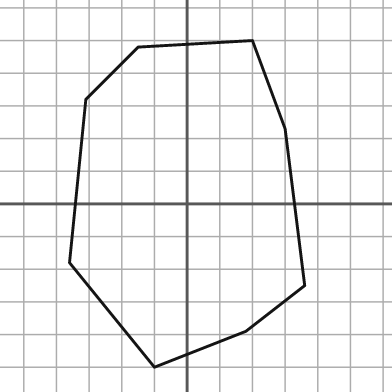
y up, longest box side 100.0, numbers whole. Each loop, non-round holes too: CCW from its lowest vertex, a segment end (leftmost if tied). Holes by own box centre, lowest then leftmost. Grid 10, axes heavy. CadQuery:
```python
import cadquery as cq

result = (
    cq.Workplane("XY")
    .moveTo(-10.0, -50.0)
    .lineTo(18.0, -39.0)
    .lineTo(36.0, -25.0)
    .lineTo(30.0, 23.0)
    .lineTo(20.0, 50.0)
    .lineTo(-15.0, 48.0)
    .lineTo(-31.0, 32.0)
    .lineTo(-36.0, -18.0)
    .close()
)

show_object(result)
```